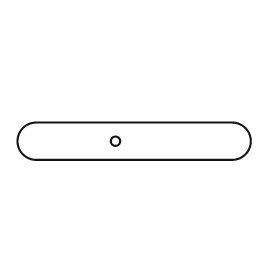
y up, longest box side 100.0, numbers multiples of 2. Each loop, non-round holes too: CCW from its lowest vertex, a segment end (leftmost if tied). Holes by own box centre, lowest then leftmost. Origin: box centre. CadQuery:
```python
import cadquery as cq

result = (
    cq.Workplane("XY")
    .moveTo(-42.0, -8.0)
    .lineTo(42.0, -8.0)
    .threePointArc((50.0, 0.0), (42.0, 8.0))
    .lineTo(-42.0, 8.0)
    .threePointArc((-50.0, 0.0), (-42.0, -8.0))
    .close()
    .moveTo(-8.0, 0.0)
    .circle(2.0)
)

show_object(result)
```